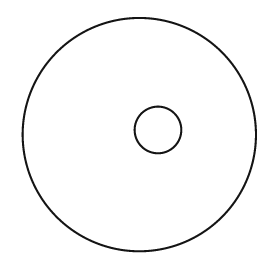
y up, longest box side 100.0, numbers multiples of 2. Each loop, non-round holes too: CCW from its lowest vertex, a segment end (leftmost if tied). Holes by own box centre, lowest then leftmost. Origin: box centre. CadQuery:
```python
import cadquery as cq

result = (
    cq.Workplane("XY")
    .moveTo(0.0, 0.0)
    .circle(50.0)
    .moveTo(8.0, 2.0)
    .circle(10.0)
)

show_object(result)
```